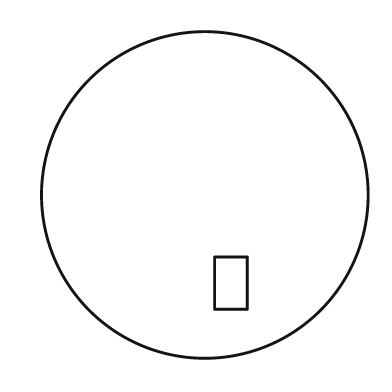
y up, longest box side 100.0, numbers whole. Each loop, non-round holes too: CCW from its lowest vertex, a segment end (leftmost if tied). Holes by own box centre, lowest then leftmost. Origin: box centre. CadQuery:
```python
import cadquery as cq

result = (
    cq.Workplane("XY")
    .moveTo(0.0, 0.0)
    .circle(50.0)
    .moveTo(3.0, -35.0)
    .lineTo(13.0, -35.0)
    .lineTo(13.0, -19.0)
    .lineTo(3.0, -19.0)
    .close()
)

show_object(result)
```